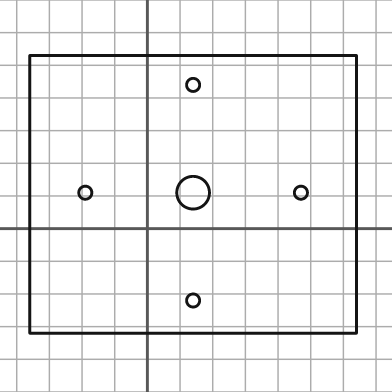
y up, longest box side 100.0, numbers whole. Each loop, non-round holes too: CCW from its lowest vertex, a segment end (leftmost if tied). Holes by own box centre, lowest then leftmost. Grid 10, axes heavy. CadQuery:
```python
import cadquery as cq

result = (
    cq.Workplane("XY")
    .moveTo(-36.0, -32.0)
    .lineTo(64.0, -32.0)
    .lineTo(64.0, 53.0)
    .lineTo(-36.0, 53.0)
    .close()
    .moveTo(14.0, -22.0)
    .circle(2.0)
    .moveTo(-19.0, 11.0)
    .circle(2.0)
    .moveTo(14.0, 11.0)
    .circle(5.0)
    .moveTo(47.0, 11.0)
    .circle(2.0)
    .moveTo(14.0, 44.0)
    .circle(2.0)
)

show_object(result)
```